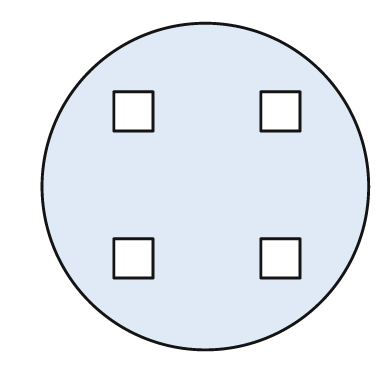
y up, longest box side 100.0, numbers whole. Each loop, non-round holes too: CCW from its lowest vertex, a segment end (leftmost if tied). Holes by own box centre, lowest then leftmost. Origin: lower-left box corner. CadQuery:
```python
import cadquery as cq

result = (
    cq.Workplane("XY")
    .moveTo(50.0, 50.0)
    .circle(50.0)
    .moveTo(22.0, 22.0)
    .lineTo(34.0, 22.0)
    .lineTo(34.0, 34.0)
    .lineTo(22.0, 34.0)
    .close()
    .moveTo(67.0, 22.0)
    .lineTo(79.0, 22.0)
    .lineTo(79.0, 34.0)
    .lineTo(67.0, 34.0)
    .close()
    .moveTo(22.0, 67.0)
    .lineTo(34.0, 67.0)
    .lineTo(34.0, 79.0)
    .lineTo(22.0, 79.0)
    .close()
    .moveTo(67.0, 67.0)
    .lineTo(79.0, 67.0)
    .lineTo(79.0, 79.0)
    .lineTo(67.0, 79.0)
    .close()
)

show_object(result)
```